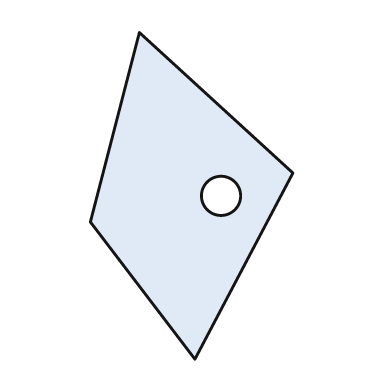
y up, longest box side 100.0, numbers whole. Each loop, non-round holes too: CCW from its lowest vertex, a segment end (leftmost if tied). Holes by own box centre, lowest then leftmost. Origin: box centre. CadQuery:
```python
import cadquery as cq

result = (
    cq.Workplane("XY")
    .moveTo(1.0, -50.0)
    .lineTo(31.0, 7.0)
    .lineTo(-16.0, 50.0)
    .lineTo(-31.0, -8.0)
    .close()
    .moveTo(9.0, 0.0)
    .circle(6.0)
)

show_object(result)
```